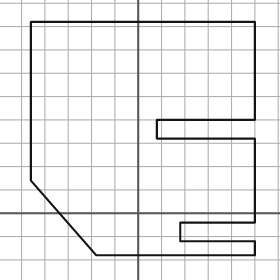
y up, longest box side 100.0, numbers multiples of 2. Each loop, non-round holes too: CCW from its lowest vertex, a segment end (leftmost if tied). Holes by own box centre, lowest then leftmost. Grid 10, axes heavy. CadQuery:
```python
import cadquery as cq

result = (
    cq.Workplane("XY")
    .moveTo(-18.0, -18.0)
    .lineTo(50.0, -18.0)
    .lineTo(50.0, -12.0)
    .lineTo(18.0, -12.0)
    .lineTo(18.0, -4.0)
    .lineTo(50.0, -4.0)
    .lineTo(50.0, 32.0)
    .lineTo(8.0, 32.0)
    .lineTo(8.0, 40.0)
    .lineTo(50.0, 40.0)
    .lineTo(50.0, 82.0)
    .lineTo(-46.0, 82.0)
    .lineTo(-46.0, 14.0)
    .close()
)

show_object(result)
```